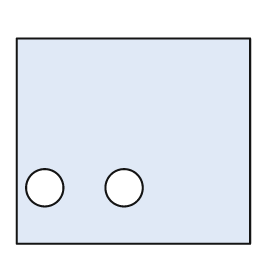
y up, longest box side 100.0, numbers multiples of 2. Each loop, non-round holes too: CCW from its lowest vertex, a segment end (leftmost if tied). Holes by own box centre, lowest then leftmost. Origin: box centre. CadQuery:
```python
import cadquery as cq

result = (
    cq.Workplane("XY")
    .moveTo(-50.0, -44.0)
    .lineTo(50.0, -44.0)
    .lineTo(50.0, 44.0)
    .lineTo(-50.0, 44.0)
    .close()
    .moveTo(-38.0, -20.0)
    .circle(8.0)
    .moveTo(-4.0, -20.0)
    .circle(8.0)
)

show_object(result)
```